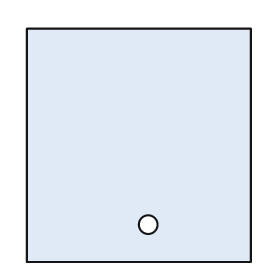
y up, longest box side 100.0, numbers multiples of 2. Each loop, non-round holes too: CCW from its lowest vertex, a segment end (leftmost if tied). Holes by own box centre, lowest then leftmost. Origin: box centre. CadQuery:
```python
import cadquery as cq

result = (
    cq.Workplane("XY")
    .moveTo(-48.0, -50.0)
    .lineTo(48.0, -50.0)
    .lineTo(48.0, 50.0)
    .lineTo(-48.0, 50.0)
    .close()
    .moveTo(4.0, -34.0)
    .circle(4.0)
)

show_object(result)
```